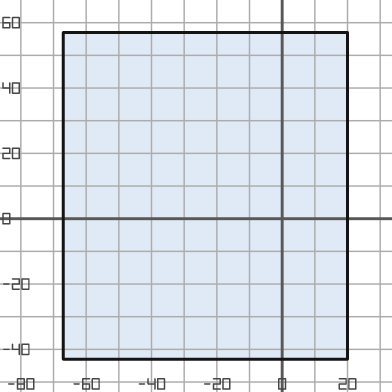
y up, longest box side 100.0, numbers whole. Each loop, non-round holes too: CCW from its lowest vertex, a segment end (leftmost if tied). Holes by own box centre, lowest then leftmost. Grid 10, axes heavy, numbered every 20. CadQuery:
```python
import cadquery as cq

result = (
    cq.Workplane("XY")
    .moveTo(-67.0, -43.0)
    .lineTo(20.0, -43.0)
    .lineTo(20.0, 57.0)
    .lineTo(-67.0, 57.0)
    .close()
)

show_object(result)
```